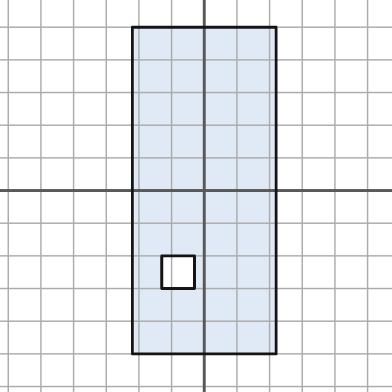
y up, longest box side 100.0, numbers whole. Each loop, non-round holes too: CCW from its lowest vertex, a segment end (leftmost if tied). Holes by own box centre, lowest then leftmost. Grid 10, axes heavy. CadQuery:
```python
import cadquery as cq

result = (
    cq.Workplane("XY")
    .moveTo(-22.0, -50.0)
    .lineTo(22.0, -50.0)
    .lineTo(22.0, 50.0)
    .lineTo(-22.0, 50.0)
    .close()
    .moveTo(-13.0, -30.0)
    .lineTo(-3.0, -30.0)
    .lineTo(-3.0, -20.0)
    .lineTo(-13.0, -20.0)
    .close()
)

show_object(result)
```